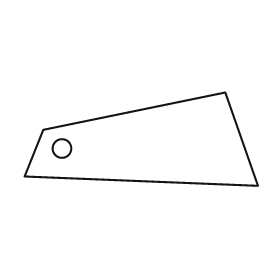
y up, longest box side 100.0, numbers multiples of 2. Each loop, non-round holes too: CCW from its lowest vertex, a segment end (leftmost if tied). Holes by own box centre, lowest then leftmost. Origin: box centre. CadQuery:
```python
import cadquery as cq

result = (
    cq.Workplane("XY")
    .moveTo(50.0, -20.0)
    .lineTo(36.0, 20.0)
    .lineTo(-42.0, 4.0)
    .lineTo(-50.0, -16.0)
    .close()
    .moveTo(-34.0, -4.0)
    .circle(4.0)
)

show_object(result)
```